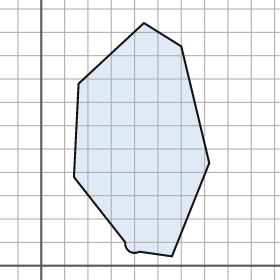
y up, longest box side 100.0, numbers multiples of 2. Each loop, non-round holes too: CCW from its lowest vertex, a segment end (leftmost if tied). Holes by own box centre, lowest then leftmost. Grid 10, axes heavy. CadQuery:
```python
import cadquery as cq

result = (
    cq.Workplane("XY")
    .moveTo(56.0, 4.0)
    .lineTo(72.0, 44.0)
    .lineTo(60.0, 94.0)
    .lineTo(44.0, 104.0)
    .lineTo(16.0, 78.0)
    .lineTo(14.0, 38.0)
    .lineTo(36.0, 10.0)
    .threePointArc((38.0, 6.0), (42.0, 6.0))
    .close()
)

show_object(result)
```